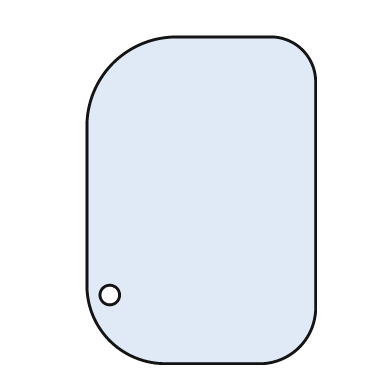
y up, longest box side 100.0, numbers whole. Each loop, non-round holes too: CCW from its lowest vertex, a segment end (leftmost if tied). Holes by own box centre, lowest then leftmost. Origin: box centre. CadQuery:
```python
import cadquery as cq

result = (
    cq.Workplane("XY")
    .moveTo(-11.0, -50.0)
    .lineTo(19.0, -50.0)
    .threePointArc((30.0, -45.0), (35.0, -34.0))
    .lineTo(35.0, 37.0)
    .threePointArc((31.0, 46.0), (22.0, 50.0))
    .lineTo(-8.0, 50.0)
    .threePointArc((-27.0, 42.0), (-35.0, 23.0))
    .lineTo(-35.0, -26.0)
    .threePointArc((-28.0, -43.0), (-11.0, -50.0))
    .close()
    .moveTo(-28.0, -29.0)
    .circle(3.0)
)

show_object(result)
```